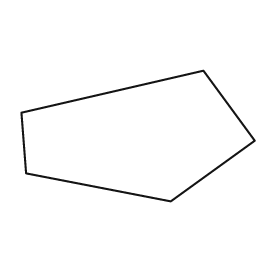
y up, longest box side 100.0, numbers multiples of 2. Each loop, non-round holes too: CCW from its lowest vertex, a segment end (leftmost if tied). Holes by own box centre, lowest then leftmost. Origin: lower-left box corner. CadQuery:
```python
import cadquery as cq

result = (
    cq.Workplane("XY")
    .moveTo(64.0, 0.0)
    .lineTo(100.0, 26.0)
    .lineTo(78.0, 56.0)
    .lineTo(0.0, 38.0)
    .lineTo(2.0, 12.0)
    .close()
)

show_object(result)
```